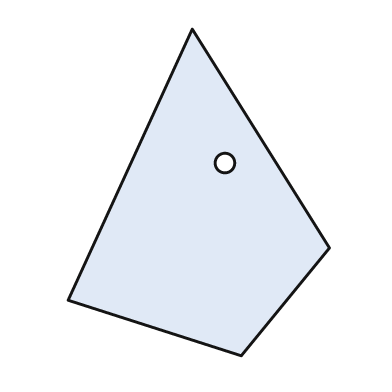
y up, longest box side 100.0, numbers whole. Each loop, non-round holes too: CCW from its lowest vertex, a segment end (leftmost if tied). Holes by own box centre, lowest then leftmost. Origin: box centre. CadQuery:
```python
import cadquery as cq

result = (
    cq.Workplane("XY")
    .moveTo(13.0, -50.0)
    .lineTo(40.0, -17.0)
    .lineTo(-2.0, 50.0)
    .lineTo(-40.0, -33.0)
    .close()
    .moveTo(8.0, 9.0)
    .circle(3.0)
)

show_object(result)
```